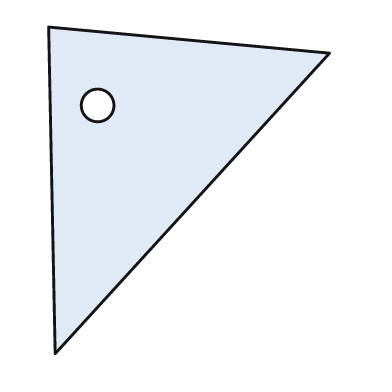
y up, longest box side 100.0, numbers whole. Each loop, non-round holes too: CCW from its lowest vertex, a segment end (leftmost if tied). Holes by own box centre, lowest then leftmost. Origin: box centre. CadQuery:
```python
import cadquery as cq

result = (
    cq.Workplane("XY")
    .moveTo(-41.0, -50.0)
    .lineTo(43.0, 42.0)
    .lineTo(-43.0, 50.0)
    .close()
    .moveTo(-28.0, 26.0)
    .circle(5.0)
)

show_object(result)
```